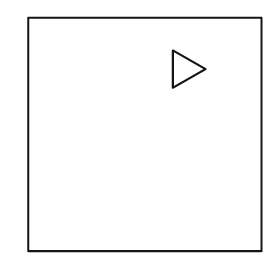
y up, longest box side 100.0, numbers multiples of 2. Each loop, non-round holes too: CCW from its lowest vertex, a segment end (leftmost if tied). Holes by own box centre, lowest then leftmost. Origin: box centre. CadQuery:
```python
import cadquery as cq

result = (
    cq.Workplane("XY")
    .moveTo(-50.0, -50.0)
    .lineTo(50.0, -50.0)
    .lineTo(50.0, 50.0)
    .lineTo(-50.0, 50.0)
    .close()
    .moveTo(12.0, 20.0)
    .lineTo(26.0, 28.0)
    .lineTo(12.0, 36.0)
    .close()
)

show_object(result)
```